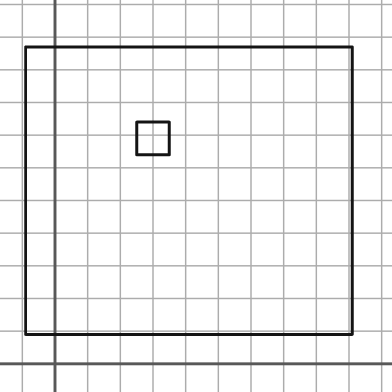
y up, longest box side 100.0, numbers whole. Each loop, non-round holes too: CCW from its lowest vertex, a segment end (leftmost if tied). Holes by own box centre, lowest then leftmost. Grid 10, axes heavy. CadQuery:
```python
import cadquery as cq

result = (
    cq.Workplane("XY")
    .moveTo(-9.0, 9.0)
    .lineTo(91.0, 9.0)
    .lineTo(91.0, 97.0)
    .lineTo(-9.0, 97.0)
    .close()
    .moveTo(25.0, 64.0)
    .lineTo(35.0, 64.0)
    .lineTo(35.0, 74.0)
    .lineTo(25.0, 74.0)
    .close()
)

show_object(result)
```